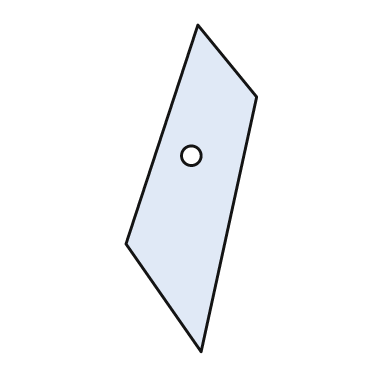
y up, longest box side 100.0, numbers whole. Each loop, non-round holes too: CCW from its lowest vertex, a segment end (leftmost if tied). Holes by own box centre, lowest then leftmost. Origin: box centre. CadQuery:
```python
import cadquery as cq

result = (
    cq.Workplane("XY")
    .moveTo(3.0, -50.0)
    .lineTo(20.0, 28.0)
    .lineTo(2.0, 50.0)
    .lineTo(-20.0, -17.0)
    .close()
    .moveTo(0.0, 10.0)
    .circle(3.0)
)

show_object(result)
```